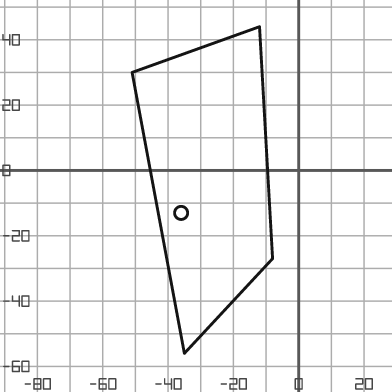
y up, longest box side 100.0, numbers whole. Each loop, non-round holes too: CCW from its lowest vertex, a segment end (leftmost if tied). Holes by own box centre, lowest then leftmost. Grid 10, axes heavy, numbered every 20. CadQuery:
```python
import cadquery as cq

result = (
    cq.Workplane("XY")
    .moveTo(-35.0, -56.0)
    .lineTo(-8.0, -27.0)
    .lineTo(-12.0, 44.0)
    .lineTo(-51.0, 30.0)
    .close()
    .moveTo(-36.0, -13.0)
    .circle(2.0)
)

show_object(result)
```